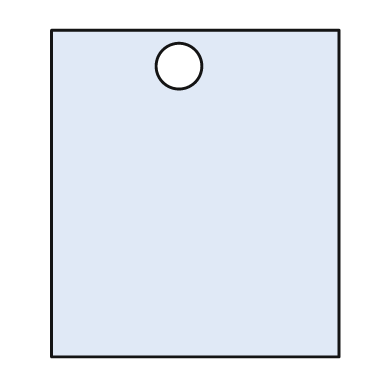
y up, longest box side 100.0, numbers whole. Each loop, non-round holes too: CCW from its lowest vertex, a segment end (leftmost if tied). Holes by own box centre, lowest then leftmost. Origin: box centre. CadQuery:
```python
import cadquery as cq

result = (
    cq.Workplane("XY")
    .moveTo(-44.0, -50.0)
    .lineTo(44.0, -50.0)
    .lineTo(44.0, 50.0)
    .lineTo(-44.0, 50.0)
    .close()
    .moveTo(-5.0, 39.0)
    .circle(7.0)
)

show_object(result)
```